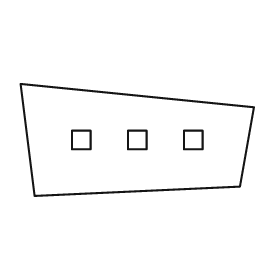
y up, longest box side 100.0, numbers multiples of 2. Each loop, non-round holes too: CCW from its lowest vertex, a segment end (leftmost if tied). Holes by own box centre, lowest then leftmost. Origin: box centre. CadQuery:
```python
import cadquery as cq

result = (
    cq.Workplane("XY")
    .moveTo(-44.0, -24.0)
    .lineTo(44.0, -20.0)
    .lineTo(50.0, 14.0)
    .lineTo(-50.0, 24.0)
    .close()
    .moveTo(-28.0, -4.0)
    .lineTo(-20.0, -4.0)
    .lineTo(-20.0, 4.0)
    .lineTo(-28.0, 4.0)
    .close()
    .moveTo(-4.0, -4.0)
    .lineTo(4.0, -4.0)
    .lineTo(4.0, 4.0)
    .lineTo(-4.0, 4.0)
    .close()
    .moveTo(20.0, -4.0)
    .lineTo(28.0, -4.0)
    .lineTo(28.0, 4.0)
    .lineTo(20.0, 4.0)
    .close()
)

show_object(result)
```